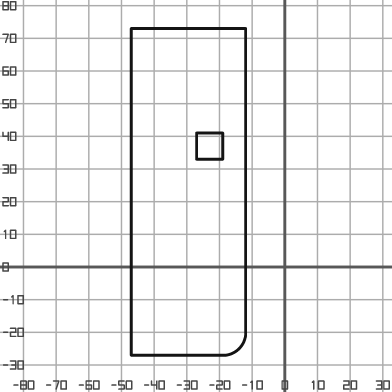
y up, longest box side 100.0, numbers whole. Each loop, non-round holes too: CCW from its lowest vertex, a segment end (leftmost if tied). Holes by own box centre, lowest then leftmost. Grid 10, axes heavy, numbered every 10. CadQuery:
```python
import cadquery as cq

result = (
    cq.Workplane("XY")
    .moveTo(-47.0, -27.0)
    .lineTo(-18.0, -27.0)
    .threePointArc((-14.0, -25.0), (-12.0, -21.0))
    .lineTo(-12.0, 73.0)
    .lineTo(-47.0, 73.0)
    .close()
    .moveTo(-27.0, 33.0)
    .lineTo(-19.0, 33.0)
    .lineTo(-19.0, 41.0)
    .lineTo(-27.0, 41.0)
    .close()
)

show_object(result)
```